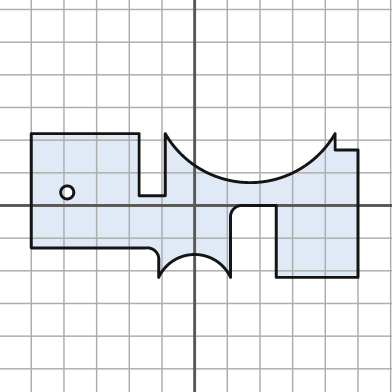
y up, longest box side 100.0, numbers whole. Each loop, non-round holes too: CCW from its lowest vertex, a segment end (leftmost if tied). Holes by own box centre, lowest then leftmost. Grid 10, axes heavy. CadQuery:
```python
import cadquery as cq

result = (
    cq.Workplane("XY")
    .moveTo(-11.0, -22.0)
    .threePointArc((0.0, -15.0), (11.0, -22.0))
    .lineTo(11.0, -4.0)
    .threePointArc((12.0, -1.0), (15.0, 0.0))
    .lineTo(25.0, 0.0)
    .lineTo(25.0, -22.0)
    .lineTo(50.0, -22.0)
    .lineTo(50.0, 17.0)
    .lineTo(43.0, 17.0)
    .lineTo(43.0, 22.0)
    .threePointArc((17.0, 7.0), (-9.0, 22.0))
    .lineTo(-9.0, 3.0)
    .lineTo(-17.0, 3.0)
    .lineTo(-17.0, 22.0)
    .lineTo(-50.0, 22.0)
    .lineTo(-50.0, -13.0)
    .lineTo(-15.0, -13.0)
    .threePointArc((-12.0, -14.0), (-11.0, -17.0))
    .close()
    .moveTo(-39.0, 4.0)
    .circle(2.0)
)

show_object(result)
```